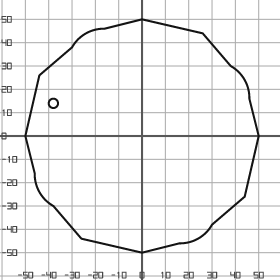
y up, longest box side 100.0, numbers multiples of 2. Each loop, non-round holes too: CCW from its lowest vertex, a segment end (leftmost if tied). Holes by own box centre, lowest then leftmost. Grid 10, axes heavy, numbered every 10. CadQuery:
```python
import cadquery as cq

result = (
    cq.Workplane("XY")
    .moveTo(0.0, -50.0)
    .lineTo(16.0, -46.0)
    .threePointArc((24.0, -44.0), (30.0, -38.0))
    .lineTo(44.0, -26.0)
    .lineTo(50.0, 0.0)
    .lineTo(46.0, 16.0)
    .threePointArc((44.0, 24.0), (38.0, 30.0))
    .lineTo(26.0, 44.0)
    .lineTo(0.0, 50.0)
    .lineTo(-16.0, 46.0)
    .threePointArc((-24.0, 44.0), (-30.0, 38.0))
    .lineTo(-44.0, 26.0)
    .lineTo(-50.0, 0.0)
    .lineTo(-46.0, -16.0)
    .threePointArc((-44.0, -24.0), (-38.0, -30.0))
    .lineTo(-26.0, -44.0)
    .close()
    .moveTo(-38.0, 14.0)
    .circle(2.0)
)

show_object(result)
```